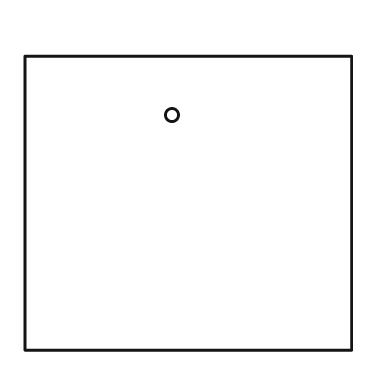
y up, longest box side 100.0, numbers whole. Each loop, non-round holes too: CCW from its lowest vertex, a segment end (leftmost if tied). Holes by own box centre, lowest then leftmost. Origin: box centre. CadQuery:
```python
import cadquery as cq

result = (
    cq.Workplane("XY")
    .moveTo(-50.0, -45.0)
    .lineTo(50.0, -45.0)
    .lineTo(50.0, 45.0)
    .lineTo(-50.0, 45.0)
    .close()
    .moveTo(-5.0, 27.0)
    .circle(2.0)
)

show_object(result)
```